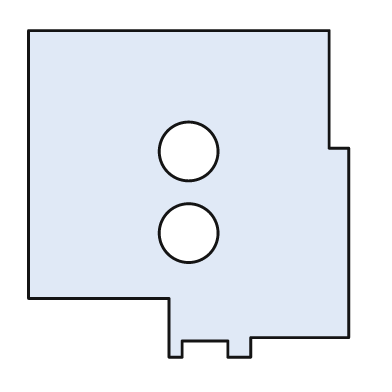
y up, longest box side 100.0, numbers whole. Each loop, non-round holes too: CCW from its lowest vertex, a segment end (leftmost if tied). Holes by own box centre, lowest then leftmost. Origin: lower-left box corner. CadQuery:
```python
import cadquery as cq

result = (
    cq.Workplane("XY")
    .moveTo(43.0, 0.0)
    .lineTo(47.0, 0.0)
    .lineTo(47.0, 5.0)
    .lineTo(61.0, 5.0)
    .lineTo(61.0, 0.0)
    .lineTo(68.0, 0.0)
    .lineTo(68.0, 6.0)
    .lineTo(98.0, 6.0)
    .lineTo(98.0, 64.0)
    .lineTo(92.0, 64.0)
    .lineTo(92.0, 100.0)
    .lineTo(0.0, 100.0)
    .lineTo(0.0, 18.0)
    .lineTo(43.0, 18.0)
    .close()
    .moveTo(49.0, 38.0)
    .circle(9.0)
    .moveTo(49.0, 63.0)
    .circle(9.0)
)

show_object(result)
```